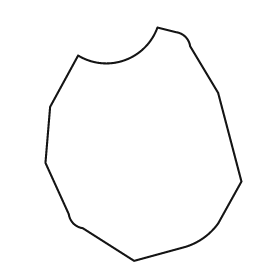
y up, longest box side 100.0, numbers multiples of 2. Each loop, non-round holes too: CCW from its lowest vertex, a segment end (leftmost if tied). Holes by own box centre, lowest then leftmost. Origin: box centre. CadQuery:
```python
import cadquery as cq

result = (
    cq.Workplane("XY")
    .moveTo(-4.0, -50.0)
    .lineTo(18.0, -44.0)
    .threePointArc((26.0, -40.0), (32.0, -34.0))
    .lineTo(42.0, -16.0)
    .lineTo(32.0, 22.0)
    .lineTo(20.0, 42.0)
    .threePointArc((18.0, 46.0), (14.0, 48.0))
    .lineTo(6.0, 50.0)
    .threePointArc((-8.0, 36.0), (-28.0, 38.0))
    .lineTo(-40.0, 16.0)
    .lineTo(-42.0, -8.0)
    .lineTo(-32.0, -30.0)
    .threePointArc((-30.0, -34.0), (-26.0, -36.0))
    .close()
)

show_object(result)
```